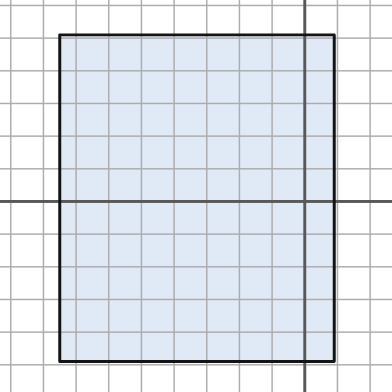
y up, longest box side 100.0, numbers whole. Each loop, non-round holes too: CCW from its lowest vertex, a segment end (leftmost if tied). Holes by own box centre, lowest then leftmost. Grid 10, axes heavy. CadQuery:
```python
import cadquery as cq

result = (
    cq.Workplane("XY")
    .moveTo(-75.0, -49.0)
    .lineTo(9.0, -49.0)
    .lineTo(9.0, 51.0)
    .lineTo(-75.0, 51.0)
    .close()
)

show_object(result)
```